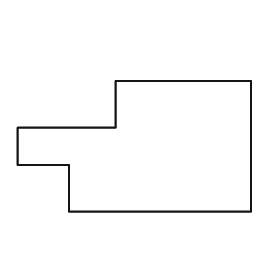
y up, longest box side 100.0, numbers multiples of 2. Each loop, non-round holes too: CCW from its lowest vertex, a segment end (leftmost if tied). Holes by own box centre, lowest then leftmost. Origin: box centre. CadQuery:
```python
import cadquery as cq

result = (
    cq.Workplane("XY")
    .moveTo(-28.0, -28.0)
    .lineTo(50.0, -28.0)
    .lineTo(50.0, 28.0)
    .lineTo(-8.0, 28.0)
    .lineTo(-8.0, 8.0)
    .lineTo(-50.0, 8.0)
    .lineTo(-50.0, -8.0)
    .lineTo(-28.0, -8.0)
    .close()
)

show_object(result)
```